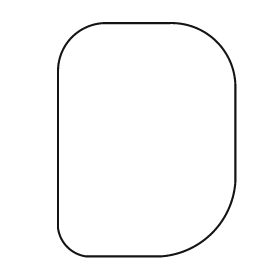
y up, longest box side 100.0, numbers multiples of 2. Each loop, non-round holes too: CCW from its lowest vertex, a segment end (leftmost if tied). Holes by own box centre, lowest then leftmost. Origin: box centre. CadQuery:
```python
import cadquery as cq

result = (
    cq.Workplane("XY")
    .moveTo(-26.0, -50.0)
    .lineTo(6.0, -50.0)
    .threePointArc((28.0, -40.0), (38.0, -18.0))
    .lineTo(38.0, 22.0)
    .threePointArc((30.0, 42.0), (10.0, 50.0))
    .lineTo(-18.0, 50.0)
    .threePointArc((-32.0, 44.0), (-38.0, 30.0))
    .lineTo(-38.0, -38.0)
    .threePointArc((-34.0, -46.0), (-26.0, -50.0))
    .close()
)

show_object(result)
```